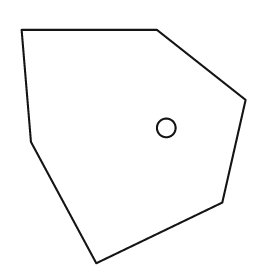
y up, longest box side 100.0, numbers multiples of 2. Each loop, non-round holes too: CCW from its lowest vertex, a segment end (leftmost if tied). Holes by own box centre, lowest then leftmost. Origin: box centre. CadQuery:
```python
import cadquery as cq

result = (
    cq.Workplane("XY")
    .moveTo(-16.0, -50.0)
    .lineTo(38.0, -24.0)
    .lineTo(48.0, 20.0)
    .lineTo(10.0, 50.0)
    .lineTo(-48.0, 50.0)
    .lineTo(-44.0, 2.0)
    .close()
    .moveTo(14.0, 8.0)
    .circle(4.0)
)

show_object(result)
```